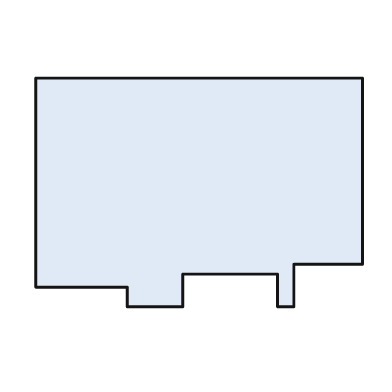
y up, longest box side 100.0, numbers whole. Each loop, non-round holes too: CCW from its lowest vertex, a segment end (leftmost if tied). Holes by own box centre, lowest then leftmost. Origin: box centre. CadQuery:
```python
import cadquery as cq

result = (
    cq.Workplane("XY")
    .moveTo(-22.0, -35.0)
    .lineTo(-5.0, -35.0)
    .lineTo(-5.0, -25.0)
    .lineTo(24.0, -25.0)
    .lineTo(24.0, -35.0)
    .lineTo(29.0, -35.0)
    .lineTo(29.0, -22.0)
    .lineTo(50.0, -22.0)
    .lineTo(50.0, 35.0)
    .lineTo(-50.0, 35.0)
    .lineTo(-50.0, -29.0)
    .lineTo(-22.0, -29.0)
    .close()
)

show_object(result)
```